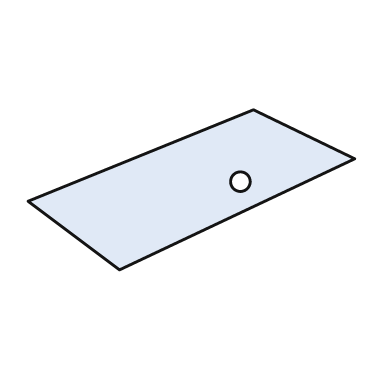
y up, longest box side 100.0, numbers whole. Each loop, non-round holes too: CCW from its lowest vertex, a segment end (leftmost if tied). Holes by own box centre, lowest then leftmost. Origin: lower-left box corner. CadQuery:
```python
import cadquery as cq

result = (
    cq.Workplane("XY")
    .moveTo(28.0, 0.0)
    .lineTo(100.0, 34.0)
    .lineTo(69.0, 49.0)
    .lineTo(0.0, 21.0)
    .close()
    .moveTo(65.0, 27.0)
    .circle(3.0)
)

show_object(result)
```